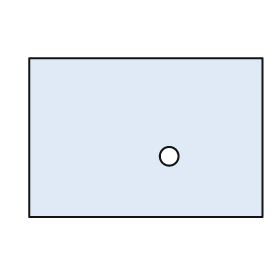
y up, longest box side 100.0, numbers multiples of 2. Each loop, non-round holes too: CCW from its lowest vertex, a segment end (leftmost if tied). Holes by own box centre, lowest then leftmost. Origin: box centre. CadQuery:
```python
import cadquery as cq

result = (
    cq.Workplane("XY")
    .moveTo(-50.0, -34.0)
    .lineTo(50.0, -34.0)
    .lineTo(50.0, 34.0)
    .lineTo(-50.0, 34.0)
    .close()
    .moveTo(10.0, -8.0)
    .circle(4.0)
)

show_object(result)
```